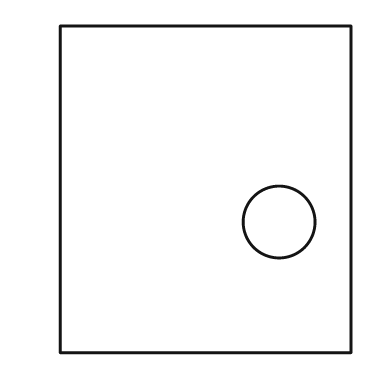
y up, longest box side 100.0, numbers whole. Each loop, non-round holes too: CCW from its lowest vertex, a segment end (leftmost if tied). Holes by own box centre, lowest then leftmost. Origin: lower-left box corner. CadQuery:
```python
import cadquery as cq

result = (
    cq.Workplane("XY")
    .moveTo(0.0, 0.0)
    .lineTo(89.0, 0.0)
    .lineTo(89.0, 100.0)
    .lineTo(0.0, 100.0)
    .close()
    .moveTo(67.0, 40.0)
    .circle(11.0)
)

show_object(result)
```